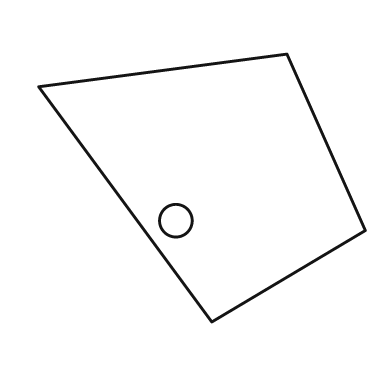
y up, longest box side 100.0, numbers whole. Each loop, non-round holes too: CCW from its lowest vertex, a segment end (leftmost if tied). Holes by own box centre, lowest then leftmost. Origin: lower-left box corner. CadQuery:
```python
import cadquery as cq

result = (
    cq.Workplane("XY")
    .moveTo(53.0, 0.0)
    .lineTo(100.0, 28.0)
    .lineTo(76.0, 82.0)
    .lineTo(0.0, 72.0)
    .close()
    .moveTo(42.0, 31.0)
    .circle(5.0)
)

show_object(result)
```